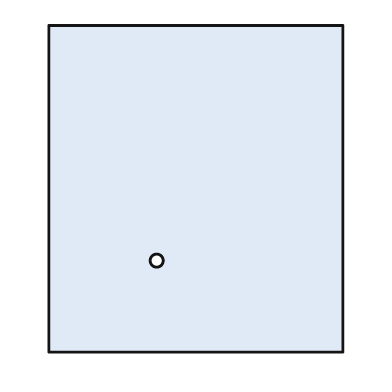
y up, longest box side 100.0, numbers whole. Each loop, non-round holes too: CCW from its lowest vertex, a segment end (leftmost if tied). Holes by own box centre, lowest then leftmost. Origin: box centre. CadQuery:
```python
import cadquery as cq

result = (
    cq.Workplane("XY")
    .moveTo(-45.0, -50.0)
    .lineTo(45.0, -50.0)
    .lineTo(45.0, 50.0)
    .lineTo(-45.0, 50.0)
    .close()
    .moveTo(-12.0, -22.0)
    .circle(2.0)
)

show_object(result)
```